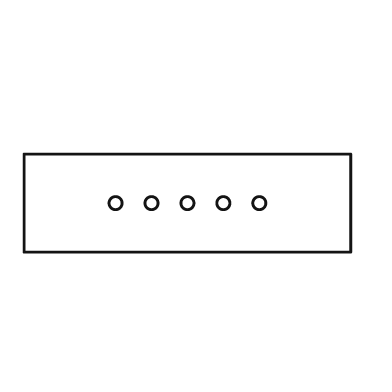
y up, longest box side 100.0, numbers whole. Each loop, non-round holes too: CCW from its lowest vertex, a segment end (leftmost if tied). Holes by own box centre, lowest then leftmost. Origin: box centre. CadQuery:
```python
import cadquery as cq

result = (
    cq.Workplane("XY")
    .moveTo(-50.0, -15.0)
    .lineTo(50.0, -15.0)
    .lineTo(50.0, 15.0)
    .lineTo(-50.0, 15.0)
    .close()
    .moveTo(-22.0, 0.0)
    .circle(2.0)
    .moveTo(-11.0, 0.0)
    .circle(2.0)
    .moveTo(0.0, 0.0)
    .circle(2.0)
    .moveTo(11.0, 0.0)
    .circle(2.0)
    .moveTo(22.0, 0.0)
    .circle(2.0)
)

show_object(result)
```